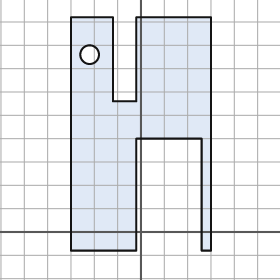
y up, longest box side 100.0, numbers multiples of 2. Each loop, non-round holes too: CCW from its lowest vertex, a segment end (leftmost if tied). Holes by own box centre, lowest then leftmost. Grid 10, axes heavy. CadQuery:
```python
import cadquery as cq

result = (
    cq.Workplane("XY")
    .moveTo(-30.0, -8.0)
    .lineTo(-2.0, -8.0)
    .lineTo(-2.0, 40.0)
    .lineTo(26.0, 40.0)
    .lineTo(26.0, -8.0)
    .lineTo(30.0, -8.0)
    .lineTo(30.0, 92.0)
    .lineTo(-2.0, 92.0)
    .lineTo(-2.0, 56.0)
    .lineTo(-12.0, 56.0)
    .lineTo(-12.0, 92.0)
    .lineTo(-30.0, 92.0)
    .close()
    .moveTo(-22.0, 76.0)
    .circle(4.0)
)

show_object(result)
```